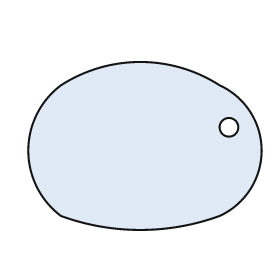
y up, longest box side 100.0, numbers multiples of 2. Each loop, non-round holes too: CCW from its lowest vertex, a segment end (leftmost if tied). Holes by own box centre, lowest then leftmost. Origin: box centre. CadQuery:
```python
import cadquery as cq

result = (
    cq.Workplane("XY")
    .moveTo(-36.0, -30.0)
    .threePointArc((-2.0, -36.0), (32.0, -30.0))
    .threePointArc((50.0, -2.0), (32.0, 26.0))
    .threePointArc((-2.0, 36.0), (-36.0, 26.0))
    .threePointArc((-50.0, -2.0), (-36.0, -30.0))
    .close()
    .moveTo(36.0, 8.0)
    .circle(4.0)
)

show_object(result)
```